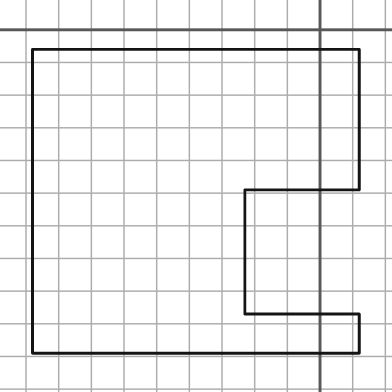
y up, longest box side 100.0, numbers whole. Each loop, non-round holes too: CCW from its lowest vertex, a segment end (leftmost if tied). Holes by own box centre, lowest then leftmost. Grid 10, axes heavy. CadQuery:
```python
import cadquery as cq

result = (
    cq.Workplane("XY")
    .moveTo(-88.0, -99.0)
    .lineTo(12.0, -99.0)
    .lineTo(12.0, -87.0)
    .lineTo(-23.0, -87.0)
    .lineTo(-23.0, -49.0)
    .lineTo(12.0, -49.0)
    .lineTo(12.0, -6.0)
    .lineTo(-88.0, -6.0)
    .close()
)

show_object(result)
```